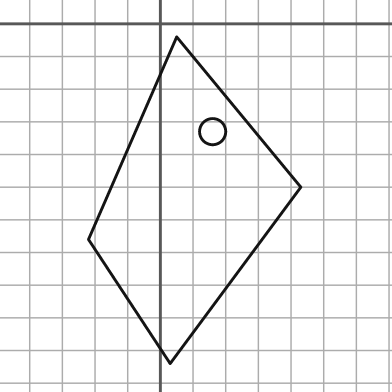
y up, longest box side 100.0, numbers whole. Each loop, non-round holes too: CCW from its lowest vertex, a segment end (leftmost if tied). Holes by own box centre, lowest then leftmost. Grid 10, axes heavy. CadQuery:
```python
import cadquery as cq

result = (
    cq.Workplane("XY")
    .moveTo(3.0, -104.0)
    .lineTo(43.0, -50.0)
    .lineTo(5.0, -4.0)
    .lineTo(-22.0, -66.0)
    .close()
    .moveTo(16.0, -33.0)
    .circle(4.0)
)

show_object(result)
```